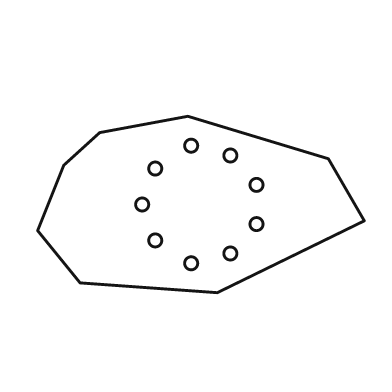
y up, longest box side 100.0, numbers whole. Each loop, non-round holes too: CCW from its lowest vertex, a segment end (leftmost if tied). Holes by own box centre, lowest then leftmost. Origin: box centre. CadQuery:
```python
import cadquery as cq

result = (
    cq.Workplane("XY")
    .moveTo(5.0, -27.0)
    .lineTo(50.0, -5.0)
    .lineTo(39.0, 14.0)
    .lineTo(-4.0, 27.0)
    .lineTo(-31.0, 22.0)
    .lineTo(-42.0, 12.0)
    .lineTo(-50.0, -8.0)
    .lineTo(-37.0, -24.0)
    .close()
    .moveTo(-3.0, -18.0)
    .circle(2.0)
    .moveTo(9.0, -15.0)
    .circle(2.0)
    .moveTo(-14.0, -11.0)
    .circle(2.0)
    .moveTo(17.0, -6.0)
    .circle(2.0)
    .moveTo(-18.0, 0.0)
    .circle(2.0)
    .moveTo(17.0, 6.0)
    .circle(2.0)
    .moveTo(-14.0, 11.0)
    .circle(2.0)
    .moveTo(9.0, 15.0)
    .circle(2.0)
    .moveTo(-3.0, 18.0)
    .circle(2.0)
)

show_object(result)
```